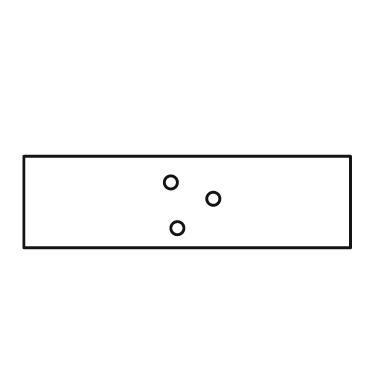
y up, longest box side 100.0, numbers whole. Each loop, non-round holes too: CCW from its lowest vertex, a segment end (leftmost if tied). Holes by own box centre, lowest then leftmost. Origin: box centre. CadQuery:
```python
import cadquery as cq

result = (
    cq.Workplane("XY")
    .moveTo(-50.0, -14.0)
    .lineTo(50.0, -14.0)
    .lineTo(50.0, 14.0)
    .lineTo(-50.0, 14.0)
    .close()
    .moveTo(-3.0, -8.0)
    .circle(2.0)
    .moveTo(8.0, 1.0)
    .circle(2.0)
    .moveTo(-5.0, 6.0)
    .circle(2.0)
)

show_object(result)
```